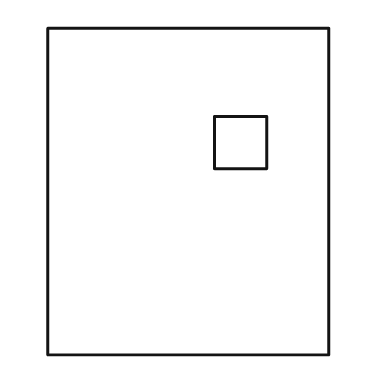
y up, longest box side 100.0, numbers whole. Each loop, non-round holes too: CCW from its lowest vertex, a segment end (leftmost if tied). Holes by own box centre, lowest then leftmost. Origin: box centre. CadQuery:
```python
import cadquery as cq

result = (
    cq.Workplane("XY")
    .moveTo(-43.0, -50.0)
    .lineTo(43.0, -50.0)
    .lineTo(43.0, 50.0)
    .lineTo(-43.0, 50.0)
    .close()
    .moveTo(8.0, 7.0)
    .lineTo(24.0, 7.0)
    .lineTo(24.0, 23.0)
    .lineTo(8.0, 23.0)
    .close()
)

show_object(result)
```